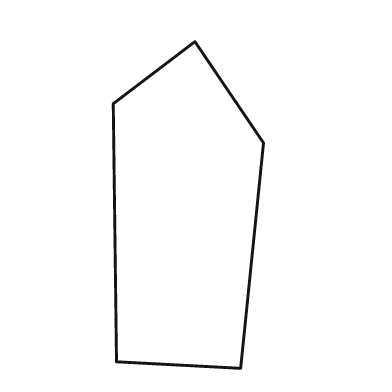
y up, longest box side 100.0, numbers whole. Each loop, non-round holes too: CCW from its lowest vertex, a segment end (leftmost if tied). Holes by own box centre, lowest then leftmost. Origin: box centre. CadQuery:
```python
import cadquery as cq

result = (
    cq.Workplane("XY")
    .moveTo(16.0, -50.0)
    .lineTo(23.0, 19.0)
    .lineTo(2.0, 50.0)
    .lineTo(-23.0, 31.0)
    .lineTo(-22.0, -48.0)
    .close()
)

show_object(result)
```